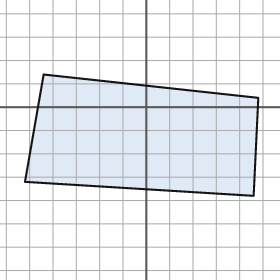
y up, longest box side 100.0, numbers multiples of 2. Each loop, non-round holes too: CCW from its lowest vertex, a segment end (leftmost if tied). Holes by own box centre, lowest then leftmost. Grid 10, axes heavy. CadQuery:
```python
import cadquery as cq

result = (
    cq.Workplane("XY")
    .moveTo(46.0, -38.0)
    .lineTo(48.0, 4.0)
    .lineTo(-44.0, 14.0)
    .lineTo(-52.0, -32.0)
    .close()
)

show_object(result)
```